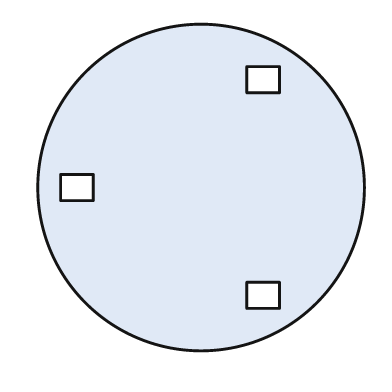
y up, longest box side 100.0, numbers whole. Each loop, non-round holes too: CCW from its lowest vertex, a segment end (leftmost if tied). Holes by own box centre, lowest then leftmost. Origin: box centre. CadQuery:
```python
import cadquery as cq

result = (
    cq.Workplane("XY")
    .moveTo(0.0, 0.0)
    .circle(50.0)
    .moveTo(14.0, -37.0)
    .lineTo(24.0, -37.0)
    .lineTo(24.0, -29.0)
    .lineTo(14.0, -29.0)
    .close()
    .moveTo(-43.0, -4.0)
    .lineTo(-33.0, -4.0)
    .lineTo(-33.0, 4.0)
    .lineTo(-43.0, 4.0)
    .close()
    .moveTo(14.0, 29.0)
    .lineTo(24.0, 29.0)
    .lineTo(24.0, 37.0)
    .lineTo(14.0, 37.0)
    .close()
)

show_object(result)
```